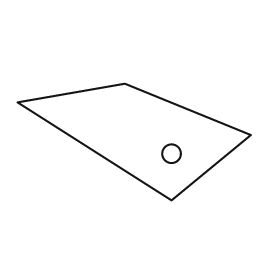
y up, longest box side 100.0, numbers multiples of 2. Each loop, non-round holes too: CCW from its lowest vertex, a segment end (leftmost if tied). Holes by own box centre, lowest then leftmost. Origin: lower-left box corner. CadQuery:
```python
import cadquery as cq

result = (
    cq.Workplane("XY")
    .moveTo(66.0, 0.0)
    .lineTo(100.0, 28.0)
    .lineTo(46.0, 50.0)
    .lineTo(0.0, 42.0)
    .close()
    .moveTo(66.0, 20.0)
    .circle(4.0)
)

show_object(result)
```